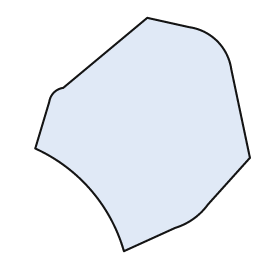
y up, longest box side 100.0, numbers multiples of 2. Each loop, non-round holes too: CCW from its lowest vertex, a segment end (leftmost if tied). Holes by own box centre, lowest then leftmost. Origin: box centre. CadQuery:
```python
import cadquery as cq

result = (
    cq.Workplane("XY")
    .moveTo(-8.0, -50.0)
    .lineTo(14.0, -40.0)
    .threePointArc((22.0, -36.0), (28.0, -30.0))
    .lineTo(46.0, -10.0)
    .lineTo(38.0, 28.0)
    .threePointArc((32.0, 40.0), (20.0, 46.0))
    .lineTo(2.0, 50.0)
    .lineTo(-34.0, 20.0)
    .threePointArc((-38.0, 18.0), (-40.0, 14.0))
    .lineTo(-46.0, -6.0)
    .threePointArc((-22.0, -24.0), (-8.0, -50.0))
    .close()
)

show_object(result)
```